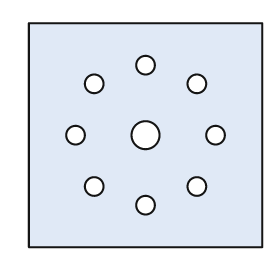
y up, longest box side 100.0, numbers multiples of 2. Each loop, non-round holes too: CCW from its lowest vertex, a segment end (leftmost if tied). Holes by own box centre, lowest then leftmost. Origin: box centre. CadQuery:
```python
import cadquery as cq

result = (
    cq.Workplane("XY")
    .moveTo(-50.0, -48.0)
    .lineTo(50.0, -48.0)
    .lineTo(50.0, 48.0)
    .lineTo(-50.0, 48.0)
    .close()
    .moveTo(0.0, -30.0)
    .circle(4.0)
    .moveTo(-22.0, -22.0)
    .circle(4.0)
    .moveTo(22.0, -22.0)
    .circle(4.0)
    .moveTo(-30.0, 0.0)
    .circle(4.0)
    .moveTo(0.0, 0.0)
    .circle(6.0)
    .moveTo(30.0, 0.0)
    .circle(4.0)
    .moveTo(-22.0, 22.0)
    .circle(4.0)
    .moveTo(22.0, 22.0)
    .circle(4.0)
    .moveTo(0.0, 30.0)
    .circle(4.0)
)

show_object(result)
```